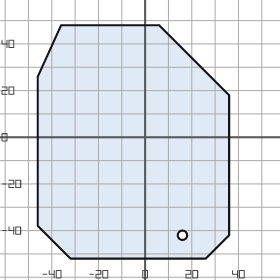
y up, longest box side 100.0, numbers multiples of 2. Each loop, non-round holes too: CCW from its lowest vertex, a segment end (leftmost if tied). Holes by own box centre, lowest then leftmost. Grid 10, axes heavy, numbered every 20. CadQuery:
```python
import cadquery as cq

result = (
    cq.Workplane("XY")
    .moveTo(-32.0, -52.0)
    .lineTo(26.0, -52.0)
    .lineTo(36.0, -42.0)
    .lineTo(36.0, 18.0)
    .lineTo(6.0, 48.0)
    .lineTo(-36.0, 48.0)
    .lineTo(-46.0, 26.0)
    .lineTo(-46.0, -38.0)
    .close()
    .moveTo(16.0, -42.0)
    .circle(2.0)
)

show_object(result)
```